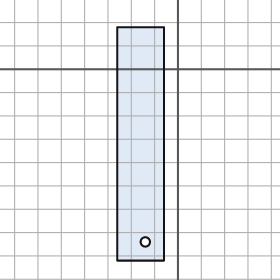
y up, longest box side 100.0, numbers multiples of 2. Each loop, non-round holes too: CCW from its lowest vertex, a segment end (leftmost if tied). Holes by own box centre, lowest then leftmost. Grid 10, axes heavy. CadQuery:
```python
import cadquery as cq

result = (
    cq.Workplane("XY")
    .moveTo(-26.0, -82.0)
    .lineTo(-6.0, -82.0)
    .lineTo(-6.0, 18.0)
    .lineTo(-26.0, 18.0)
    .close()
    .moveTo(-14.0, -74.0)
    .circle(2.0)
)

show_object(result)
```